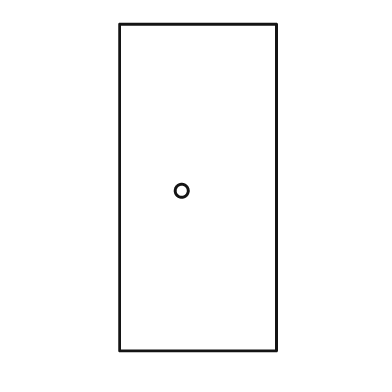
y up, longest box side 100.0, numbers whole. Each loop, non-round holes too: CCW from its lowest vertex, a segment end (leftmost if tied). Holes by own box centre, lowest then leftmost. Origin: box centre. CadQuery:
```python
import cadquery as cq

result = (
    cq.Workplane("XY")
    .moveTo(-24.0, -50.0)
    .lineTo(24.0, -50.0)
    .lineTo(24.0, 50.0)
    .lineTo(-24.0, 50.0)
    .close()
    .moveTo(-5.0, -1.0)
    .circle(2.0)
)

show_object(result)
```